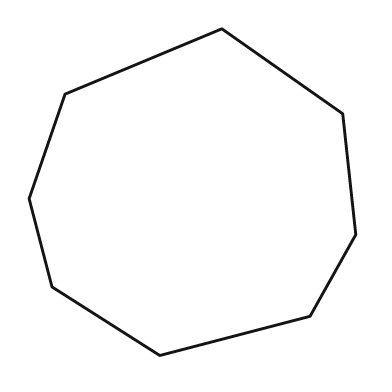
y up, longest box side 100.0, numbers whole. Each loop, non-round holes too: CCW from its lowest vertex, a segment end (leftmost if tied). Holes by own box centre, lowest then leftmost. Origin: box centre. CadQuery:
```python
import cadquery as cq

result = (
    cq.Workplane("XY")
    .moveTo(-10.0, -50.0)
    .lineTo(36.0, -38.0)
    .lineTo(50.0, -13.0)
    .lineTo(46.0, 24.0)
    .lineTo(9.0, 50.0)
    .lineTo(-39.0, 30.0)
    .lineTo(-50.0, -2.0)
    .lineTo(-43.0, -29.0)
    .close()
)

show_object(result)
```